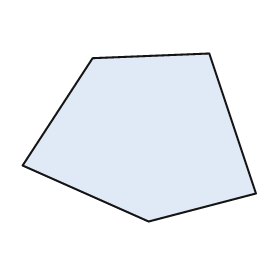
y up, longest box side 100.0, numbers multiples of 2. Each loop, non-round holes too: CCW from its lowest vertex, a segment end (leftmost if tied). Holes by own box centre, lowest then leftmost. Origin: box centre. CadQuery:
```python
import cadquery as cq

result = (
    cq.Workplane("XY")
    .moveTo(4.0, -36.0)
    .lineTo(50.0, -24.0)
    .lineTo(30.0, 36.0)
    .lineTo(-20.0, 34.0)
    .lineTo(-50.0, -12.0)
    .close()
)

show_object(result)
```